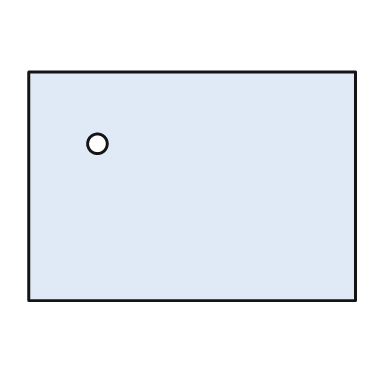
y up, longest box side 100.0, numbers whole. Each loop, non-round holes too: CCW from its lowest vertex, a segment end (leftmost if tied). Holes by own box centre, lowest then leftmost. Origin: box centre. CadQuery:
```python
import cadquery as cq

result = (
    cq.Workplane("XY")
    .moveTo(-50.0, -35.0)
    .lineTo(50.0, -35.0)
    .lineTo(50.0, 35.0)
    .lineTo(-50.0, 35.0)
    .close()
    .moveTo(-29.0, 13.0)
    .circle(3.0)
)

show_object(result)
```